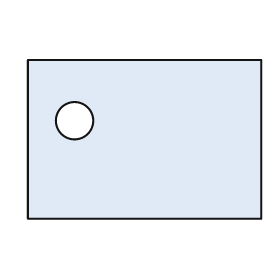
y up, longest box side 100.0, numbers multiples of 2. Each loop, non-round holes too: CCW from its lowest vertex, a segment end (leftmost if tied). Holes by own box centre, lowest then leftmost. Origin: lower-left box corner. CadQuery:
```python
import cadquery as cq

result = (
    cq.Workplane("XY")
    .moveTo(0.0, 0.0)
    .lineTo(100.0, 0.0)
    .lineTo(100.0, 68.0)
    .lineTo(0.0, 68.0)
    .close()
    .moveTo(20.0, 42.0)
    .circle(8.0)
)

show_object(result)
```